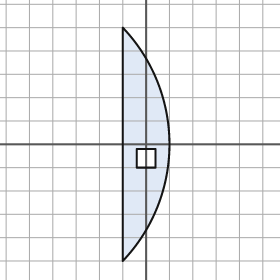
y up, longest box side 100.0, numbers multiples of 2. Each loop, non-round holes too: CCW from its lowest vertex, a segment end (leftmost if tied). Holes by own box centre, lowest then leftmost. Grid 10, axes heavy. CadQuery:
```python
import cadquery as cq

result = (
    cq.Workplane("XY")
    .moveTo(-10.0, -50.0)
    .threePointArc((10.0, 0.0), (-10.0, 50.0))
    .close()
    .moveTo(-4.0, -10.0)
    .lineTo(4.0, -10.0)
    .lineTo(4.0, -2.0)
    .lineTo(-4.0, -2.0)
    .close()
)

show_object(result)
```